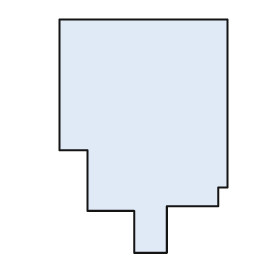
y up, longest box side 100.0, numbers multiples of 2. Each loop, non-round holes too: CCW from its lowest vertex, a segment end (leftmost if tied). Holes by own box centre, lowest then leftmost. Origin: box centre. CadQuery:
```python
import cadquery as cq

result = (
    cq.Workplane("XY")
    .moveTo(-4.0, -50.0)
    .lineTo(10.0, -50.0)
    .lineTo(10.0, -30.0)
    .lineTo(32.0, -30.0)
    .lineTo(32.0, -22.0)
    .lineTo(36.0, -22.0)
    .lineTo(36.0, 50.0)
    .lineTo(-36.0, 50.0)
    .lineTo(-36.0, -6.0)
    .lineTo(-24.0, -6.0)
    .lineTo(-24.0, -32.0)
    .lineTo(-4.0, -32.0)
    .close()
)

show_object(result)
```